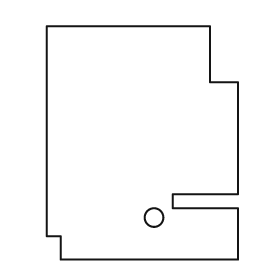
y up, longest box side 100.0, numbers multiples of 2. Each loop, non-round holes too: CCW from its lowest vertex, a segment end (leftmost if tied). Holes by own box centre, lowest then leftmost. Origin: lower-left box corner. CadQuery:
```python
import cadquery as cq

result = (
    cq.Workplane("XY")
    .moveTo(6.0, 0.0)
    .lineTo(82.0, 0.0)
    .lineTo(82.0, 22.0)
    .lineTo(54.0, 22.0)
    .lineTo(54.0, 28.0)
    .lineTo(82.0, 28.0)
    .lineTo(82.0, 76.0)
    .lineTo(70.0, 76.0)
    .lineTo(70.0, 100.0)
    .lineTo(0.0, 100.0)
    .lineTo(0.0, 10.0)
    .lineTo(6.0, 10.0)
    .close()
    .moveTo(46.0, 18.0)
    .circle(4.0)
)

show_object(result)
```